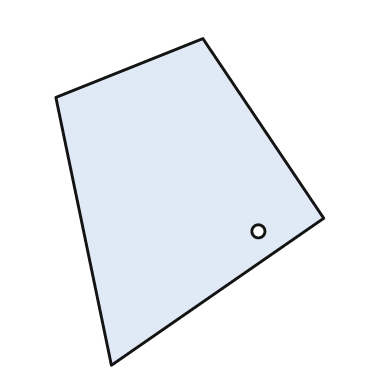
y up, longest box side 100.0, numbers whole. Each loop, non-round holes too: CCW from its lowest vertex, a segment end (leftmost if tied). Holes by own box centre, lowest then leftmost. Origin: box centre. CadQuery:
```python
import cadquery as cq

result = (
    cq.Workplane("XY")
    .moveTo(-24.0, -50.0)
    .lineTo(41.0, -5.0)
    .lineTo(4.0, 50.0)
    .lineTo(-41.0, 32.0)
    .close()
    .moveTo(21.0, -9.0)
    .circle(2.0)
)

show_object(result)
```